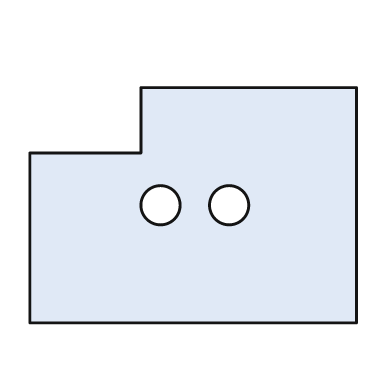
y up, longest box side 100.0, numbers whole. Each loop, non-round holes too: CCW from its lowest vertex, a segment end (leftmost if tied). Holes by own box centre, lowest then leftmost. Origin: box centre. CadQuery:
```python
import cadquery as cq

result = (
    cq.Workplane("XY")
    .moveTo(-50.0, -36.0)
    .lineTo(50.0, -36.0)
    .lineTo(50.0, 36.0)
    .lineTo(-16.0, 36.0)
    .lineTo(-16.0, 16.0)
    .lineTo(-50.0, 16.0)
    .close()
    .moveTo(-10.0, 0.0)
    .circle(6.0)
    .moveTo(11.0, 0.0)
    .circle(6.0)
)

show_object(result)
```